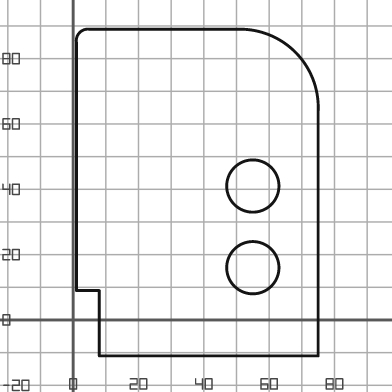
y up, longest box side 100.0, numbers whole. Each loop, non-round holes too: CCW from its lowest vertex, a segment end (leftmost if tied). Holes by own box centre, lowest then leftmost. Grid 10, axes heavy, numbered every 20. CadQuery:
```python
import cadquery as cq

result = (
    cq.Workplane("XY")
    .moveTo(8.0, -11.0)
    .lineTo(75.0, -11.0)
    .lineTo(75.0, 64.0)
    .threePointArc((68.0, 82.0), (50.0, 89.0))
    .lineTo(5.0, 89.0)
    .threePointArc((2.0, 88.0), (1.0, 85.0))
    .lineTo(1.0, 9.0)
    .lineTo(8.0, 9.0)
    .close()
    .moveTo(55.0, 16.0)
    .circle(8.0)
    .moveTo(55.0, 41.0)
    .circle(8.0)
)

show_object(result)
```